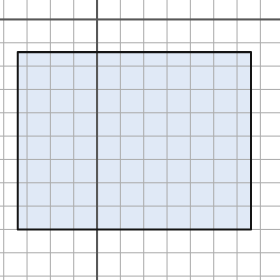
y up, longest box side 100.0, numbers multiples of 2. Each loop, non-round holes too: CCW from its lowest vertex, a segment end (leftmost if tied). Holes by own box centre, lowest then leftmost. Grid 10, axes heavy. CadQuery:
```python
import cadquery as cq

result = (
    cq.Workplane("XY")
    .moveTo(-34.0, -90.0)
    .lineTo(66.0, -90.0)
    .lineTo(66.0, -14.0)
    .lineTo(-34.0, -14.0)
    .close()
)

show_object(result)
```